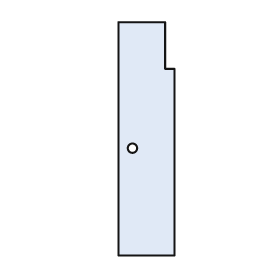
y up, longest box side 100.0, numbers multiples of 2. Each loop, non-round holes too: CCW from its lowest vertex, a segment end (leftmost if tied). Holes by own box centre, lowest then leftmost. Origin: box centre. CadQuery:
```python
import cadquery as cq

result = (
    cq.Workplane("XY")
    .moveTo(-12.0, -50.0)
    .lineTo(12.0, -50.0)
    .lineTo(12.0, 30.0)
    .lineTo(8.0, 30.0)
    .lineTo(8.0, 50.0)
    .lineTo(-12.0, 50.0)
    .close()
    .moveTo(-6.0, -4.0)
    .circle(2.0)
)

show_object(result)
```